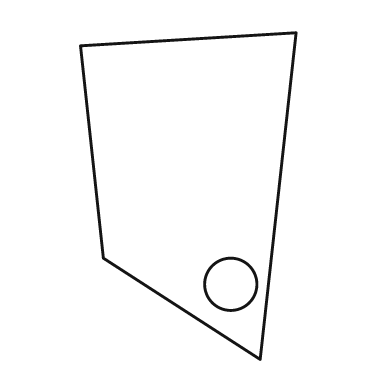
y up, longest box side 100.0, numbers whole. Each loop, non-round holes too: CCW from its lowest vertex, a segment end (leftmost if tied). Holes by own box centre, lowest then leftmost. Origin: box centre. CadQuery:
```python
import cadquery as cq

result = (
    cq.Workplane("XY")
    .moveTo(22.0, -50.0)
    .lineTo(33.0, 50.0)
    .lineTo(-33.0, 46.0)
    .lineTo(-26.0, -19.0)
    .close()
    .moveTo(13.0, -27.0)
    .circle(8.0)
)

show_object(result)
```